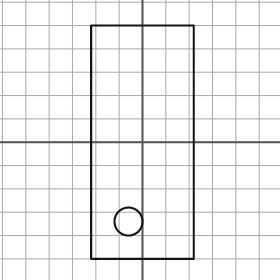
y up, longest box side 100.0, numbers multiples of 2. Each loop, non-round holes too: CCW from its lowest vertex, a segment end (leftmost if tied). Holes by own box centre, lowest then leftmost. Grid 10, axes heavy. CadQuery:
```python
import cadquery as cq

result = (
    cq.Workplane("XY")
    .moveTo(-22.0, -50.0)
    .lineTo(22.0, -50.0)
    .lineTo(22.0, 50.0)
    .lineTo(-22.0, 50.0)
    .close()
    .moveTo(-6.0, -34.0)
    .circle(6.0)
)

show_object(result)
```